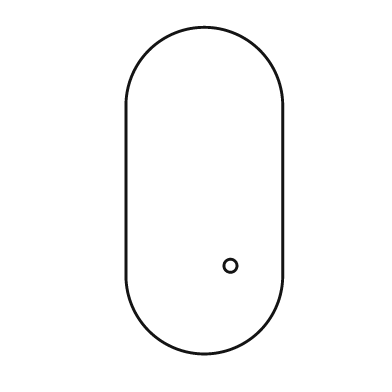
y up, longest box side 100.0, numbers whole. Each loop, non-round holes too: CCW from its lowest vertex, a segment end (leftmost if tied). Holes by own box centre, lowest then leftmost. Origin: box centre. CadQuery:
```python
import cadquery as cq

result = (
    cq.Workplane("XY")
    .moveTo(-24.0, -26.0)
    .threePointArc((0.0, -50.0), (24.0, -26.0))
    .lineTo(24.0, 26.0)
    .threePointArc((0.0, 50.0), (-24.0, 26.0))
    .close()
    .moveTo(8.0, -23.0)
    .circle(2.0)
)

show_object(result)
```